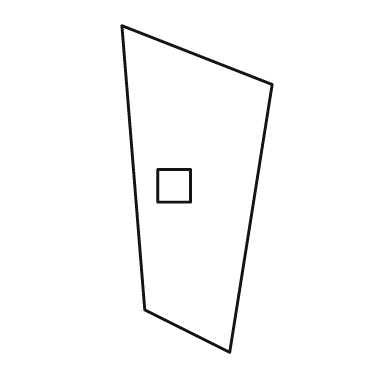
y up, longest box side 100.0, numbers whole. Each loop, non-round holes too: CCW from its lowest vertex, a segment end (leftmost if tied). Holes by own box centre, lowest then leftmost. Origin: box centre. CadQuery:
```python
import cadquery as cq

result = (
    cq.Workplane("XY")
    .moveTo(10.0, -50.0)
    .lineTo(23.0, 32.0)
    .lineTo(-23.0, 50.0)
    .lineTo(-16.0, -37.0)
    .close()
    .moveTo(-12.0, -4.0)
    .lineTo(-2.0, -4.0)
    .lineTo(-2.0, 6.0)
    .lineTo(-12.0, 6.0)
    .close()
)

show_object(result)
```